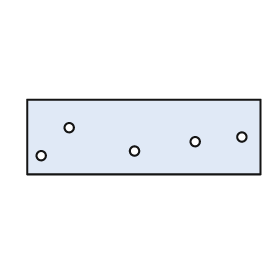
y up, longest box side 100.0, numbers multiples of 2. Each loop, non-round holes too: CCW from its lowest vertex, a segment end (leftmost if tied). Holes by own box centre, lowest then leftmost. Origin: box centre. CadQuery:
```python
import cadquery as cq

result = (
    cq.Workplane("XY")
    .moveTo(-50.0, -16.0)
    .lineTo(50.0, -16.0)
    .lineTo(50.0, 16.0)
    .lineTo(-50.0, 16.0)
    .close()
    .moveTo(-44.0, -8.0)
    .circle(2.0)
    .moveTo(-4.0, -6.0)
    .circle(2.0)
    .moveTo(22.0, -2.0)
    .circle(2.0)
    .moveTo(42.0, 0.0)
    .circle(2.0)
    .moveTo(-32.0, 4.0)
    .circle(2.0)
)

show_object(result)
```